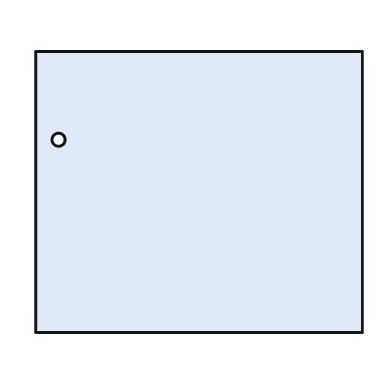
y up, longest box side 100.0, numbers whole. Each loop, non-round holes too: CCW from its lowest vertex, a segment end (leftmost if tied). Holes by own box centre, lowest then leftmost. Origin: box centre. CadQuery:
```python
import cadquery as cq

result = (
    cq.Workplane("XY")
    .moveTo(-50.0, -43.0)
    .lineTo(50.0, -43.0)
    .lineTo(50.0, 43.0)
    .lineTo(-50.0, 43.0)
    .close()
    .moveTo(-43.0, 16.0)
    .circle(2.0)
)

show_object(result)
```